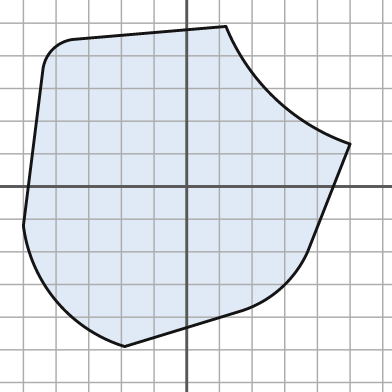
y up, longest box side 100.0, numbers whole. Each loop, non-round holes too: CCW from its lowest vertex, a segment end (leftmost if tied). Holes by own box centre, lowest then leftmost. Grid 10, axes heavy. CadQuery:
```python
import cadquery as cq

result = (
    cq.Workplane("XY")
    .moveTo(-19.0, -49.0)
    .lineTo(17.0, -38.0)
    .threePointArc((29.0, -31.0), (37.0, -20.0))
    .lineTo(50.0, 13.0)
    .threePointArc((27.0, 27.0), (12.0, 49.0))
    .lineTo(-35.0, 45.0)
    .threePointArc((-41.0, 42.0), (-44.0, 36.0))
    .lineTo(-50.0, -12.0)
    .threePointArc((-40.0, -35.0), (-19.0, -49.0))
    .close()
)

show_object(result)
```